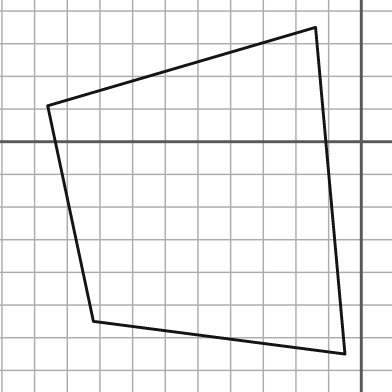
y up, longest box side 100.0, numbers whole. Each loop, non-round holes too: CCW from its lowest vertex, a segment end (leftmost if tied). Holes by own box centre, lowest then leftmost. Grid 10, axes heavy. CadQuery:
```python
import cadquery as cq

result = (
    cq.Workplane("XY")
    .moveTo(-5.0, -65.0)
    .lineTo(-14.0, 35.0)
    .lineTo(-96.0, 11.0)
    .lineTo(-82.0, -55.0)
    .close()
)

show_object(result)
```